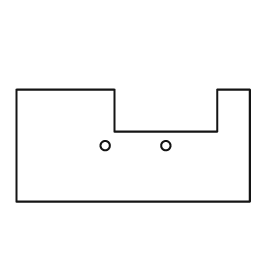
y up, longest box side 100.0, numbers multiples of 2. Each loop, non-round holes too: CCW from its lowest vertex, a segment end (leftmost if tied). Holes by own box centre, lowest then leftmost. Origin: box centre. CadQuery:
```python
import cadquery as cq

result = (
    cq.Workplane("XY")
    .moveTo(-50.0, -24.0)
    .lineTo(50.0, -24.0)
    .lineTo(50.0, 24.0)
    .lineTo(36.0, 24.0)
    .lineTo(36.0, 6.0)
    .lineTo(-8.0, 6.0)
    .lineTo(-8.0, 24.0)
    .lineTo(-50.0, 24.0)
    .close()
    .moveTo(-12.0, 0.0)
    .circle(2.0)
    .moveTo(14.0, 0.0)
    .circle(2.0)
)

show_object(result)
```